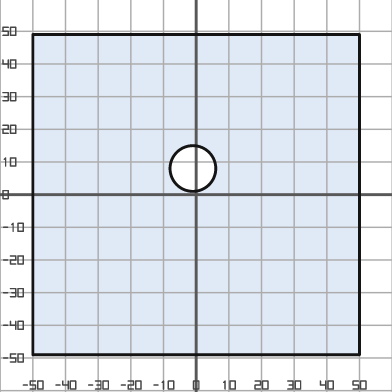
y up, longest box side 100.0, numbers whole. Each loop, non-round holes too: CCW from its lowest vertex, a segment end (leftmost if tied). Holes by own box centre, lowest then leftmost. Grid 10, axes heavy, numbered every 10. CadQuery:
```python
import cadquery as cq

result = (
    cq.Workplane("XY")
    .moveTo(-50.0, -49.0)
    .lineTo(50.0, -49.0)
    .lineTo(50.0, 49.0)
    .lineTo(-50.0, 49.0)
    .close()
    .moveTo(-1.0, 8.0)
    .circle(7.0)
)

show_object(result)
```